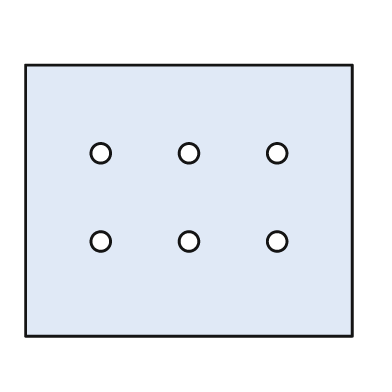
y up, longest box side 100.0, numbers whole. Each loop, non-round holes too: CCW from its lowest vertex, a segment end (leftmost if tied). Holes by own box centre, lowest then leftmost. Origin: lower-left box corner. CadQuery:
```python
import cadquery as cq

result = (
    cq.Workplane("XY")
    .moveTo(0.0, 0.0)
    .lineTo(100.0, 0.0)
    .lineTo(100.0, 83.0)
    .lineTo(0.0, 83.0)
    .close()
    .moveTo(23.0, 29.0)
    .circle(3.0)
    .moveTo(50.0, 29.0)
    .circle(3.0)
    .moveTo(77.0, 29.0)
    .circle(3.0)
    .moveTo(23.0, 56.0)
    .circle(3.0)
    .moveTo(50.0, 56.0)
    .circle(3.0)
    .moveTo(77.0, 56.0)
    .circle(3.0)
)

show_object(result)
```